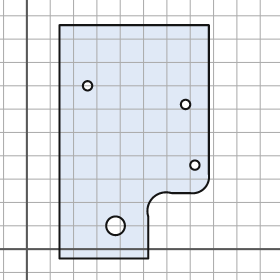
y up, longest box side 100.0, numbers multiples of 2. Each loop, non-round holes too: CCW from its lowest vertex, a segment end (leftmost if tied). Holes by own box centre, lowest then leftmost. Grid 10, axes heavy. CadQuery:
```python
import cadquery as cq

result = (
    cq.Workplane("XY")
    .moveTo(14.0, -4.0)
    .lineTo(52.0, -4.0)
    .lineTo(52.0, 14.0)
    .threePointArc((54.0, 22.0), (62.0, 24.0))
    .lineTo(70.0, 24.0)
    .threePointArc((76.0, 26.0), (78.0, 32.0))
    .lineTo(78.0, 96.0)
    .lineTo(14.0, 96.0)
    .close()
    .moveTo(38.0, 10.0)
    .circle(4.0)
    .moveTo(72.0, 36.0)
    .circle(2.0)
    .moveTo(68.0, 62.0)
    .circle(2.0)
    .moveTo(26.0, 70.0)
    .circle(2.0)
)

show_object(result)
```